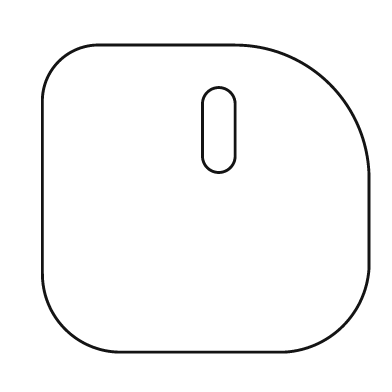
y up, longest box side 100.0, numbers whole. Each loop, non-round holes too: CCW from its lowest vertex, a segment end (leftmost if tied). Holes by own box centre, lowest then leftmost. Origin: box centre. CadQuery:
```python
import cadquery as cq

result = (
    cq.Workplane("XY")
    .moveTo(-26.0, -47.0)
    .lineTo(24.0, -47.0)
    .threePointArc((42.0, -39.0), (50.0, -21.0))
    .lineTo(50.0, 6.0)
    .threePointArc((38.0, 35.0), (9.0, 47.0))
    .lineTo(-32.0, 47.0)
    .threePointArc((-45.0, 42.0), (-50.0, 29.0))
    .lineTo(-50.0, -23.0)
    .threePointArc((-43.0, -40.0), (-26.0, -47.0))
    .close()
    .moveTo(-1.0, 13.0)
    .threePointArc((4.0, 8.0), (9.0, 13.0))
    .lineTo(9.0, 29.0)
    .threePointArc((4.0, 34.0), (-1.0, 29.0))
    .close()
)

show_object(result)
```